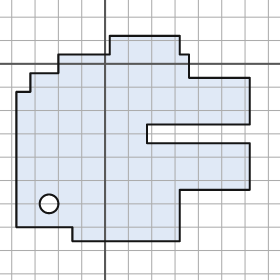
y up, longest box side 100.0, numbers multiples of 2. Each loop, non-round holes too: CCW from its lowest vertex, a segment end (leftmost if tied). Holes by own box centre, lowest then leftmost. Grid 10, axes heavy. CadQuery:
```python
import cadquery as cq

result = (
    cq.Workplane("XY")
    .moveTo(-14.0, -76.0)
    .lineTo(32.0, -76.0)
    .lineTo(32.0, -54.0)
    .lineTo(62.0, -54.0)
    .lineTo(62.0, -34.0)
    .lineTo(18.0, -34.0)
    .lineTo(18.0, -26.0)
    .lineTo(62.0, -26.0)
    .lineTo(62.0, -6.0)
    .lineTo(36.0, -6.0)
    .lineTo(36.0, 4.0)
    .lineTo(32.0, 4.0)
    .lineTo(32.0, 12.0)
    .lineTo(2.0, 12.0)
    .lineTo(2.0, 4.0)
    .lineTo(-20.0, 4.0)
    .lineTo(-20.0, -4.0)
    .lineTo(-32.0, -4.0)
    .lineTo(-32.0, -12.0)
    .lineTo(-38.0, -12.0)
    .lineTo(-38.0, -70.0)
    .lineTo(-14.0, -70.0)
    .close()
    .moveTo(-24.0, -60.0)
    .circle(4.0)
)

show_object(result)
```